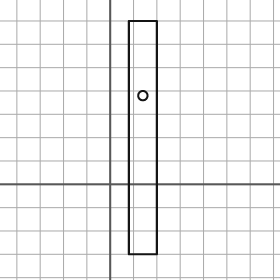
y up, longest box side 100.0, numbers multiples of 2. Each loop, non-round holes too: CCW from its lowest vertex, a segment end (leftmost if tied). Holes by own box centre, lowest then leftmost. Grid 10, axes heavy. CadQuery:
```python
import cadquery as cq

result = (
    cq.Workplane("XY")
    .moveTo(8.0, -30.0)
    .lineTo(20.0, -30.0)
    .lineTo(20.0, 70.0)
    .lineTo(8.0, 70.0)
    .close()
    .moveTo(14.0, 38.0)
    .circle(2.0)
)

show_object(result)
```